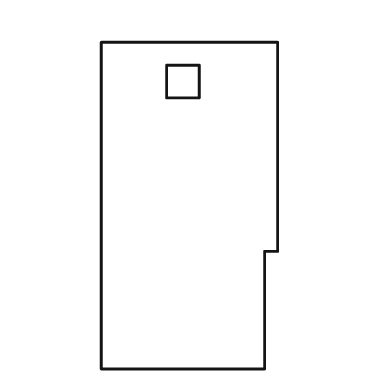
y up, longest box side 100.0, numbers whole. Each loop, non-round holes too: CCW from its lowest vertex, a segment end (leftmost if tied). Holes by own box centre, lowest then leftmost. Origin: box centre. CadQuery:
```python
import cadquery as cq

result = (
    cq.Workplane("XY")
    .moveTo(-27.0, -50.0)
    .lineTo(23.0, -50.0)
    .lineTo(23.0, -14.0)
    .lineTo(27.0, -14.0)
    .lineTo(27.0, 50.0)
    .lineTo(-27.0, 50.0)
    .close()
    .moveTo(-7.0, 33.0)
    .lineTo(3.0, 33.0)
    .lineTo(3.0, 43.0)
    .lineTo(-7.0, 43.0)
    .close()
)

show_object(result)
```